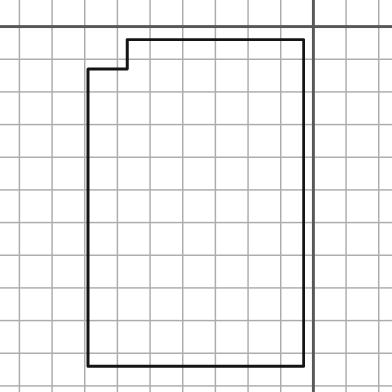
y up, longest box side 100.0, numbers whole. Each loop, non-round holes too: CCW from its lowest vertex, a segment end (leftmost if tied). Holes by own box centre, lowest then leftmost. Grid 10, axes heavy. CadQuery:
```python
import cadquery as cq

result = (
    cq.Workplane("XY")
    .moveTo(-69.0, -104.0)
    .lineTo(-3.0, -104.0)
    .lineTo(-3.0, -4.0)
    .lineTo(-57.0, -4.0)
    .lineTo(-57.0, -13.0)
    .lineTo(-69.0, -13.0)
    .close()
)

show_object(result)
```